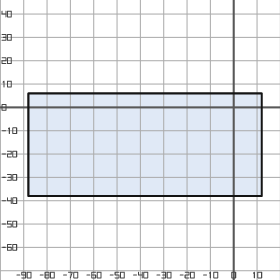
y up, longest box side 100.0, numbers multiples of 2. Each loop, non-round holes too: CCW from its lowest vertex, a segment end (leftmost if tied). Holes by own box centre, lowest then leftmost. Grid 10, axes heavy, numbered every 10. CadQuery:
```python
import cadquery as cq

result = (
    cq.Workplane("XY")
    .moveTo(-88.0, -38.0)
    .lineTo(12.0, -38.0)
    .lineTo(12.0, 6.0)
    .lineTo(-88.0, 6.0)
    .close()
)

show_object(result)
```